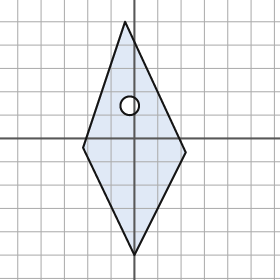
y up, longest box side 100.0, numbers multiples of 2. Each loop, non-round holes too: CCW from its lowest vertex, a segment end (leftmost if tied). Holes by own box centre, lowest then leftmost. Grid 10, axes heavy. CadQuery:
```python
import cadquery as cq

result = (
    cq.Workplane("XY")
    .moveTo(0.0, -50.0)
    .lineTo(22.0, -6.0)
    .lineTo(-4.0, 50.0)
    .lineTo(-22.0, -4.0)
    .close()
    .moveTo(-2.0, 14.0)
    .circle(4.0)
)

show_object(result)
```